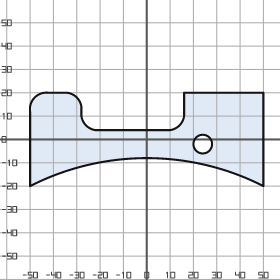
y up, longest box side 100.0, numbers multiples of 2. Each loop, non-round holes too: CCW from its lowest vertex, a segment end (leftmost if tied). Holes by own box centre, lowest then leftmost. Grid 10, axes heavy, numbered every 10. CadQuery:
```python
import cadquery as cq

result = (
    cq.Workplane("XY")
    .moveTo(-50.0, -20.0)
    .threePointArc((0.0, -8.0), (50.0, -20.0))
    .lineTo(50.0, 20.0)
    .lineTo(16.0, 20.0)
    .lineTo(16.0, 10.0)
    .threePointArc((14.0, 6.0), (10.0, 4.0))
    .lineTo(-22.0, 4.0)
    .threePointArc((-26.0, 6.0), (-28.0, 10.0))
    .lineTo(-28.0, 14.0)
    .threePointArc((-30.0, 18.0), (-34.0, 20.0))
    .lineTo(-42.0, 20.0)
    .threePointArc((-48.0, 18.0), (-50.0, 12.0))
    .close()
    .moveTo(24.0, -2.0)
    .circle(4.0)
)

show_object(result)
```